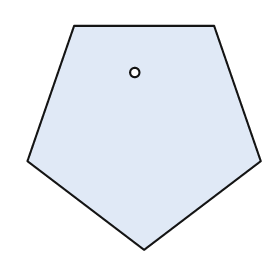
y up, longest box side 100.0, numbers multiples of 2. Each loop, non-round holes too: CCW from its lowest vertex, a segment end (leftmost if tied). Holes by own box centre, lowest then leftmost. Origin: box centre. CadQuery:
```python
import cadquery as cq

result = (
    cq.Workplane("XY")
    .moveTo(0.0, -48.0)
    .lineTo(50.0, -10.0)
    .lineTo(30.0, 48.0)
    .lineTo(-30.0, 48.0)
    .lineTo(-50.0, -10.0)
    .close()
    .moveTo(-4.0, 28.0)
    .circle(2.0)
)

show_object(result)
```